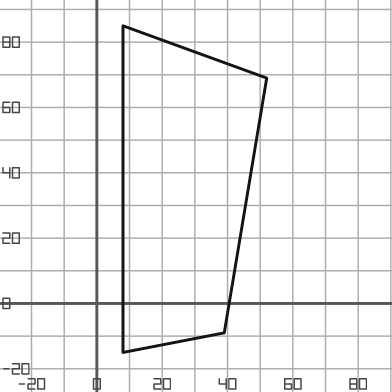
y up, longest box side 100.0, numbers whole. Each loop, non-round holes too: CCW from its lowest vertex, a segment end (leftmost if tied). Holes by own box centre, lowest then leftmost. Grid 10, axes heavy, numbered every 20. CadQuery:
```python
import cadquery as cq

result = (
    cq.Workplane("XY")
    .moveTo(8.0, -15.0)
    .lineTo(39.0, -9.0)
    .lineTo(52.0, 69.0)
    .lineTo(8.0, 85.0)
    .close()
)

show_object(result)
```